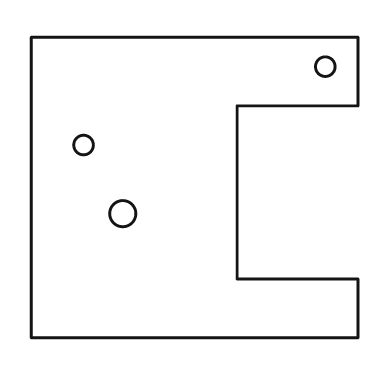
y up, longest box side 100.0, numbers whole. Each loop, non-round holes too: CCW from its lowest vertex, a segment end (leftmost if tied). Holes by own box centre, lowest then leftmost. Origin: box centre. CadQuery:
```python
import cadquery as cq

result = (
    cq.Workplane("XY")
    .moveTo(-50.0, -46.0)
    .lineTo(50.0, -46.0)
    .lineTo(50.0, -28.0)
    .lineTo(13.0, -28.0)
    .lineTo(13.0, 25.0)
    .lineTo(50.0, 25.0)
    .lineTo(50.0, 46.0)
    .lineTo(-50.0, 46.0)
    .close()
    .moveTo(-22.0, -8.0)
    .circle(4.0)
    .moveTo(-34.0, 13.0)
    .circle(3.0)
    .moveTo(40.0, 37.0)
    .circle(3.0)
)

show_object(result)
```